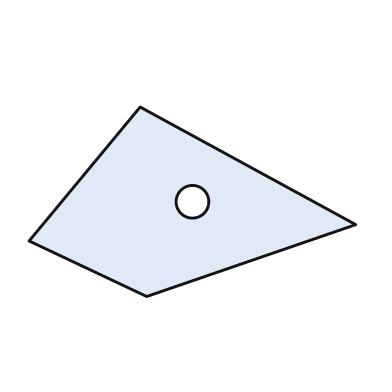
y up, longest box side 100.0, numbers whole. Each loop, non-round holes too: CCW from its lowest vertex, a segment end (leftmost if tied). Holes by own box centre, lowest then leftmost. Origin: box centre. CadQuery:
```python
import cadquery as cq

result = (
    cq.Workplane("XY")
    .moveTo(-14.0, -29.0)
    .lineTo(50.0, -7.0)
    .lineTo(-16.0, 29.0)
    .lineTo(-50.0, -12.0)
    .close()
    .moveTo(0.0, 0.0)
    .circle(5.0)
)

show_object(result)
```